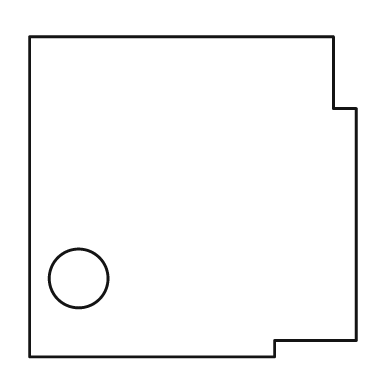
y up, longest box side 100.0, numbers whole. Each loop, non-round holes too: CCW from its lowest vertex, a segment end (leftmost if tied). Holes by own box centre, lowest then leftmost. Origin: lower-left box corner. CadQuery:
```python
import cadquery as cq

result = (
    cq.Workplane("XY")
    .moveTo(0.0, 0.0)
    .lineTo(75.0, 0.0)
    .lineTo(75.0, 5.0)
    .lineTo(100.0, 5.0)
    .lineTo(100.0, 76.0)
    .lineTo(93.0, 76.0)
    .lineTo(93.0, 98.0)
    .lineTo(0.0, 98.0)
    .close()
    .moveTo(15.0, 24.0)
    .circle(9.0)
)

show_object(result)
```